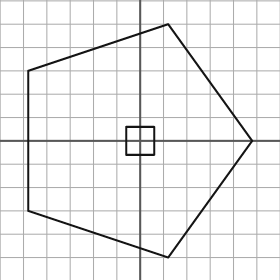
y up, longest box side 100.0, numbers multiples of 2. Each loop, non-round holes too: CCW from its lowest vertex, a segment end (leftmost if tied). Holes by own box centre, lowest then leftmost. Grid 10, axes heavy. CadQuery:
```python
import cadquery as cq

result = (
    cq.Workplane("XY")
    .moveTo(12.0, -50.0)
    .lineTo(48.0, 0.0)
    .lineTo(12.0, 50.0)
    .lineTo(-48.0, 30.0)
    .lineTo(-48.0, -30.0)
    .close()
    .moveTo(-6.0, -6.0)
    .lineTo(6.0, -6.0)
    .lineTo(6.0, 6.0)
    .lineTo(-6.0, 6.0)
    .close()
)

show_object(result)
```